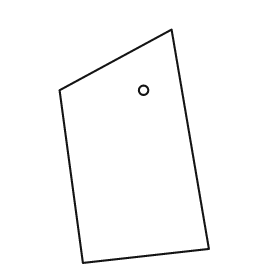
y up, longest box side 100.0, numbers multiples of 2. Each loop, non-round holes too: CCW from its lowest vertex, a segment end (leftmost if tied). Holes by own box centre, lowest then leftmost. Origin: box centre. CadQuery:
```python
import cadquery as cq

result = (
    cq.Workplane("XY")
    .moveTo(-22.0, -50.0)
    .lineTo(32.0, -44.0)
    .lineTo(16.0, 50.0)
    .lineTo(-32.0, 24.0)
    .close()
    .moveTo(4.0, 24.0)
    .circle(2.0)
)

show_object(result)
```